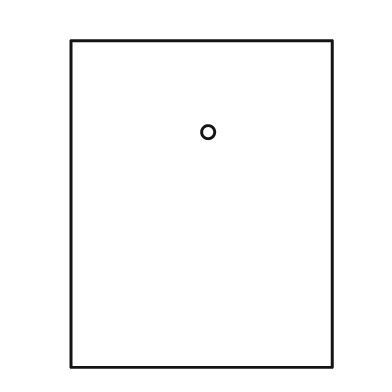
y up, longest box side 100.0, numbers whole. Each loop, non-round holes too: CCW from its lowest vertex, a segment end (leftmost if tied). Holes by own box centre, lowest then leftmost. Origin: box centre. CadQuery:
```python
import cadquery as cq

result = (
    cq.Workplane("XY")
    .moveTo(-40.0, -50.0)
    .lineTo(40.0, -50.0)
    .lineTo(40.0, 50.0)
    .lineTo(-40.0, 50.0)
    .close()
    .moveTo(2.0, 22.0)
    .circle(2.0)
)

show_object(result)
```